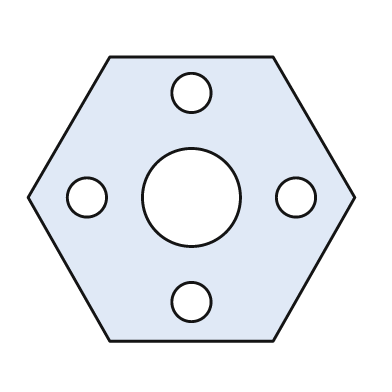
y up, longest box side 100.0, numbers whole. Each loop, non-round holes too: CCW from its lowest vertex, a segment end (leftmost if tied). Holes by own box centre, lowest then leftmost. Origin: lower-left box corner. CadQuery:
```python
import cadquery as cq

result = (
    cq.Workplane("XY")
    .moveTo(25.0, 0.0)
    .lineTo(75.0, 0.0)
    .lineTo(100.0, 44.0)
    .lineTo(75.0, 87.0)
    .lineTo(25.0, 87.0)
    .lineTo(0.0, 44.0)
    .close()
    .moveTo(50.0, 12.0)
    .circle(6.0)
    .moveTo(18.0, 44.0)
    .circle(6.0)
    .moveTo(50.0, 44.0)
    .circle(15.0)
    .moveTo(82.0, 44.0)
    .circle(6.0)
    .moveTo(50.0, 76.0)
    .circle(6.0)
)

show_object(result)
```